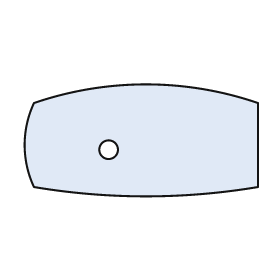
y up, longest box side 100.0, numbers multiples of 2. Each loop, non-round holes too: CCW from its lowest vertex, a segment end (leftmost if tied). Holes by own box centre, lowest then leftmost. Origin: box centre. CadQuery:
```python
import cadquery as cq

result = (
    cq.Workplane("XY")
    .moveTo(-46.0, -20.0)
    .threePointArc((2.0, -24.0), (50.0, -20.0))
    .lineTo(50.0, 16.0)
    .threePointArc((2.0, 24.0), (-46.0, 16.0))
    .threePointArc((-50.0, -2.0), (-46.0, -20.0))
    .close()
    .moveTo(-14.0, -4.0)
    .circle(4.0)
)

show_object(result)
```